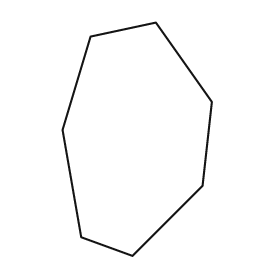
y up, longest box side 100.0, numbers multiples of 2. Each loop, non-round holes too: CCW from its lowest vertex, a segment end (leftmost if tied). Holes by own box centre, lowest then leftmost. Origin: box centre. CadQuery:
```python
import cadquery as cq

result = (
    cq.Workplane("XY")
    .moveTo(-2.0, -50.0)
    .lineTo(28.0, -20.0)
    .lineTo(32.0, 16.0)
    .lineTo(8.0, 50.0)
    .lineTo(-20.0, 44.0)
    .lineTo(-32.0, 4.0)
    .lineTo(-24.0, -42.0)
    .close()
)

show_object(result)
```